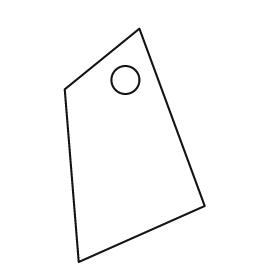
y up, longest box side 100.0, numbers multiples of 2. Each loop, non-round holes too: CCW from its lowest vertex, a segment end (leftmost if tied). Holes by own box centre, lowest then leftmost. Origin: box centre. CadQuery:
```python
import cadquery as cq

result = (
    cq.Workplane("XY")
    .moveTo(-24.0, -50.0)
    .lineTo(30.0, -26.0)
    .lineTo(2.0, 50.0)
    .lineTo(-30.0, 24.0)
    .close()
    .moveTo(-4.0, 28.0)
    .circle(6.0)
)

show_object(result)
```